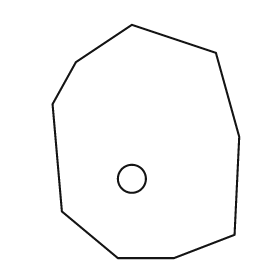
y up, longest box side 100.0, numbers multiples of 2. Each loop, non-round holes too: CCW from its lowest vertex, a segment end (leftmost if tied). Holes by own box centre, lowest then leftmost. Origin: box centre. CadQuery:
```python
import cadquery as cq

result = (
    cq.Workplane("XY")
    .moveTo(-12.0, -50.0)
    .lineTo(12.0, -50.0)
    .lineTo(38.0, -40.0)
    .lineTo(40.0, 2.0)
    .lineTo(30.0, 38.0)
    .lineTo(-6.0, 50.0)
    .lineTo(-30.0, 34.0)
    .lineTo(-40.0, 16.0)
    .lineTo(-36.0, -30.0)
    .close()
    .moveTo(-6.0, -16.0)
    .circle(6.0)
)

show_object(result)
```